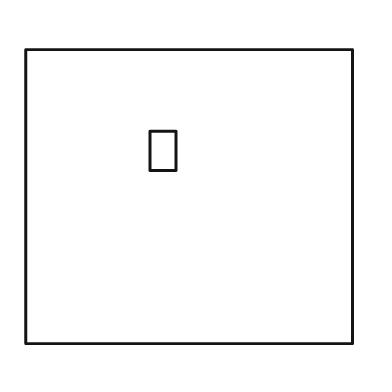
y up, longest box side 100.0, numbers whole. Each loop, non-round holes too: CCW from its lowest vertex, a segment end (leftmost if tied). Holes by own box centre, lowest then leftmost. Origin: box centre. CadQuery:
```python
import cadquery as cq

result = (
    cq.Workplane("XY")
    .moveTo(-50.0, -45.0)
    .lineTo(50.0, -45.0)
    .lineTo(50.0, 45.0)
    .lineTo(-50.0, 45.0)
    .close()
    .moveTo(-12.0, 8.0)
    .lineTo(-4.0, 8.0)
    .lineTo(-4.0, 20.0)
    .lineTo(-12.0, 20.0)
    .close()
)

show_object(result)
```